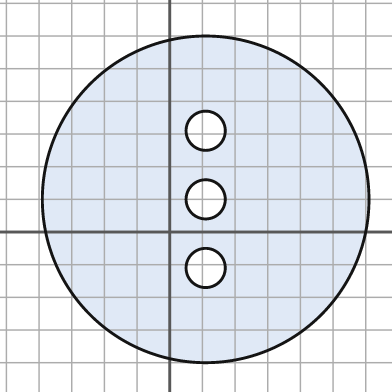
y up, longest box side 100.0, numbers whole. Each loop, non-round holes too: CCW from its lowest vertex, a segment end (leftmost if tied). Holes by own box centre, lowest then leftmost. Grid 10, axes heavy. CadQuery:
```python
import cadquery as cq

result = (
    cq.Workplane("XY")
    .moveTo(11.0, 10.0)
    .circle(50.0)
    .moveTo(11.0, -11.0)
    .circle(6.0)
    .moveTo(11.0, 10.0)
    .circle(6.0)
    .moveTo(11.0, 31.0)
    .circle(6.0)
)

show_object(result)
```